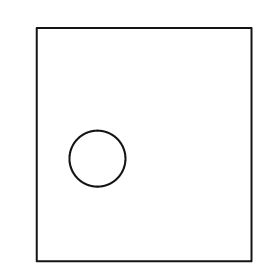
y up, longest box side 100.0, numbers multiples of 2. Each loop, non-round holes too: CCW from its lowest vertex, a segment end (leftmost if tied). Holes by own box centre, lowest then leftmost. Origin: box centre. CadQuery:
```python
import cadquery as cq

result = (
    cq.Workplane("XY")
    .moveTo(-46.0, -50.0)
    .lineTo(46.0, -50.0)
    .lineTo(46.0, 50.0)
    .lineTo(-46.0, 50.0)
    .close()
    .moveTo(-20.0, -6.0)
    .circle(12.0)
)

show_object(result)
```